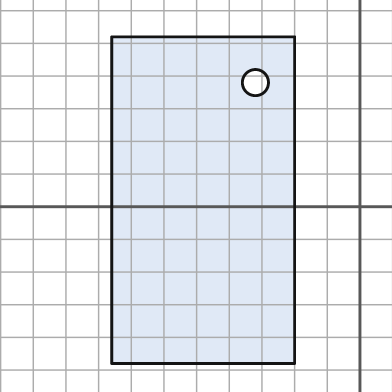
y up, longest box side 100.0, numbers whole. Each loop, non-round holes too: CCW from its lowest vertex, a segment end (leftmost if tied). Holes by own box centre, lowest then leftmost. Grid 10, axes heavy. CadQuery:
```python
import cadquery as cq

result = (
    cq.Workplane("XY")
    .moveTo(-76.0, -48.0)
    .lineTo(-20.0, -48.0)
    .lineTo(-20.0, 52.0)
    .lineTo(-76.0, 52.0)
    .close()
    .moveTo(-32.0, 38.0)
    .circle(4.0)
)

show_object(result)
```